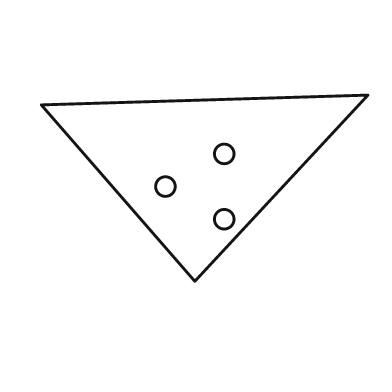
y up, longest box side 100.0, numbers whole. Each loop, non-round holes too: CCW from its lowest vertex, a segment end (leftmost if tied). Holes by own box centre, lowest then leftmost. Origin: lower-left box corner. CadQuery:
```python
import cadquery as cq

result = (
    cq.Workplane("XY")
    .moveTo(47.0, 0.0)
    .lineTo(100.0, 57.0)
    .lineTo(0.0, 54.0)
    .close()
    .moveTo(56.0, 19.0)
    .circle(3.0)
    .moveTo(38.0, 29.0)
    .circle(3.0)
    .moveTo(56.0, 39.0)
    .circle(3.0)
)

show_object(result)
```